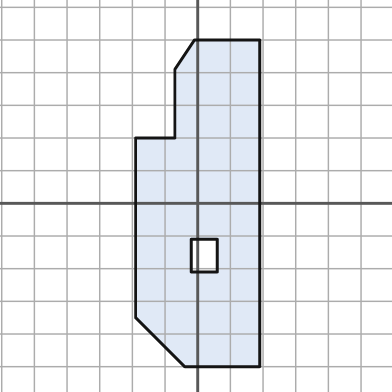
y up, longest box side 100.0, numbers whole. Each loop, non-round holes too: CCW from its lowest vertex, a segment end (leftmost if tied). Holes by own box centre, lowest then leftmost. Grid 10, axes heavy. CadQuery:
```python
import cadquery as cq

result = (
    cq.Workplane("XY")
    .moveTo(-4.0, -50.0)
    .lineTo(19.0, -50.0)
    .lineTo(19.0, 50.0)
    .lineTo(-1.0, 50.0)
    .lineTo(-7.0, 41.0)
    .lineTo(-7.0, 20.0)
    .lineTo(-19.0, 20.0)
    .lineTo(-19.0, -35.0)
    .close()
    .moveTo(-2.0, -21.0)
    .lineTo(6.0, -21.0)
    .lineTo(6.0, -11.0)
    .lineTo(-2.0, -11.0)
    .close()
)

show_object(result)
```